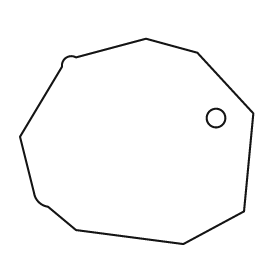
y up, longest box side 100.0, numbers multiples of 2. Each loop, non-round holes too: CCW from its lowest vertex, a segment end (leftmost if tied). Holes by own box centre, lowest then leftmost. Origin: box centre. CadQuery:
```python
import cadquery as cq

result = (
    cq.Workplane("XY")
    .moveTo(20.0, -44.0)
    .lineTo(46.0, -30.0)
    .lineTo(50.0, 12.0)
    .lineTo(26.0, 38.0)
    .lineTo(4.0, 44.0)
    .lineTo(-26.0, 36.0)
    .threePointArc((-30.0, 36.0), (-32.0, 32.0))
    .lineTo(-50.0, 2.0)
    .lineTo(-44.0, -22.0)
    .threePointArc((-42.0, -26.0), (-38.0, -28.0))
    .lineTo(-26.0, -38.0)
    .close()
    .moveTo(34.0, 10.0)
    .circle(4.0)
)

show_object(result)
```